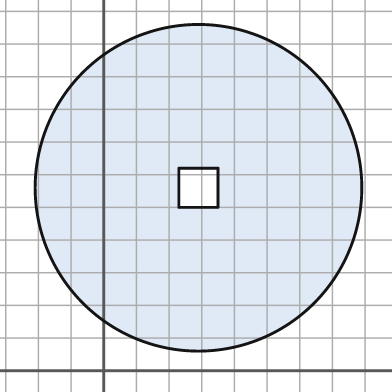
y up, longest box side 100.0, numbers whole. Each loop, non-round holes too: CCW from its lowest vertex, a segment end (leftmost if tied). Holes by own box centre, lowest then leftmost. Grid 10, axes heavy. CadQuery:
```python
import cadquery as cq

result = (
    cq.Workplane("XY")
    .moveTo(29.0, 56.0)
    .circle(50.0)
    .moveTo(23.0, 50.0)
    .lineTo(35.0, 50.0)
    .lineTo(35.0, 62.0)
    .lineTo(23.0, 62.0)
    .close()
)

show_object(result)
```